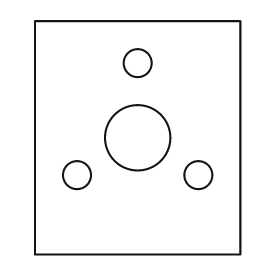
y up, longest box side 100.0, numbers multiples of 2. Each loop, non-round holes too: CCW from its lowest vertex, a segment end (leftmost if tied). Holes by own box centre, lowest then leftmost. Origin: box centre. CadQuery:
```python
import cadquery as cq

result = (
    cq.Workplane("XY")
    .moveTo(-44.0, -50.0)
    .lineTo(44.0, -50.0)
    .lineTo(44.0, 50.0)
    .lineTo(-44.0, 50.0)
    .close()
    .moveTo(-26.0, -16.0)
    .circle(6.0)
    .moveTo(26.0, -16.0)
    .circle(6.0)
    .moveTo(0.0, 0.0)
    .circle(14.0)
    .moveTo(0.0, 32.0)
    .circle(6.0)
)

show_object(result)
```